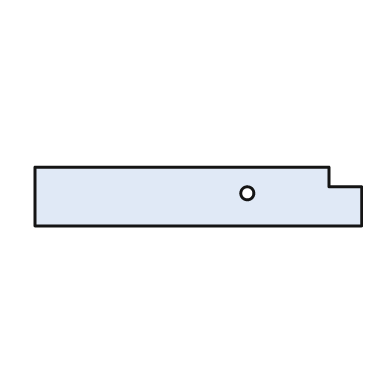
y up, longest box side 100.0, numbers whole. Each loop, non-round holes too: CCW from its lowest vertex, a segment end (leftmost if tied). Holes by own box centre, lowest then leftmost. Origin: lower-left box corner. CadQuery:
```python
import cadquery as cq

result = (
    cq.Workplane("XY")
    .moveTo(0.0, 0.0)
    .lineTo(100.0, 0.0)
    .lineTo(100.0, 12.0)
    .lineTo(90.0, 12.0)
    .lineTo(90.0, 18.0)
    .lineTo(0.0, 18.0)
    .close()
    .moveTo(65.0, 10.0)
    .circle(2.0)
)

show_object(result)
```